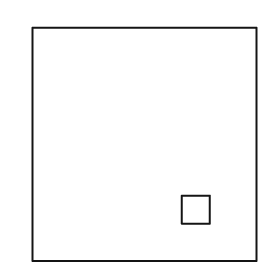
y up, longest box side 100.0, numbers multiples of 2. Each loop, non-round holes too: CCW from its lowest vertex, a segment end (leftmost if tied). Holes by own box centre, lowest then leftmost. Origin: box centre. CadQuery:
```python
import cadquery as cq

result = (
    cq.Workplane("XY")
    .moveTo(-48.0, -50.0)
    .lineTo(48.0, -50.0)
    .lineTo(48.0, 50.0)
    .lineTo(-48.0, 50.0)
    .close()
    .moveTo(16.0, -34.0)
    .lineTo(28.0, -34.0)
    .lineTo(28.0, -22.0)
    .lineTo(16.0, -22.0)
    .close()
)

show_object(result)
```